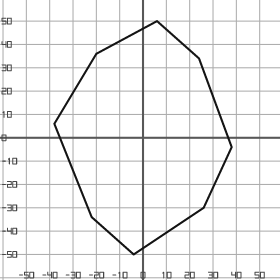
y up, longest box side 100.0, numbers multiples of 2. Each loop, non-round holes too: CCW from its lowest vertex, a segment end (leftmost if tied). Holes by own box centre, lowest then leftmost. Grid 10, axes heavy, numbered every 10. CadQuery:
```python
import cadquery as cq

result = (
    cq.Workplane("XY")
    .moveTo(-4.0, -50.0)
    .lineTo(26.0, -30.0)
    .lineTo(38.0, -4.0)
    .lineTo(24.0, 34.0)
    .lineTo(6.0, 50.0)
    .lineTo(-20.0, 36.0)
    .lineTo(-38.0, 6.0)
    .lineTo(-22.0, -34.0)
    .close()
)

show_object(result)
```